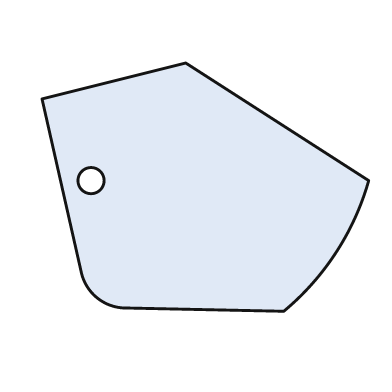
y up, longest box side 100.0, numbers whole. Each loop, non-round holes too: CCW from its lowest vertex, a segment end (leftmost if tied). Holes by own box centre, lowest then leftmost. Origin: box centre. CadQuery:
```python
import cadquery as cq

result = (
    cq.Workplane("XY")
    .moveTo(24.0, -38.0)
    .threePointArc((40.0, -20.0), (50.0, 2.0))
    .lineTo(-6.0, 38.0)
    .lineTo(-50.0, 27.0)
    .lineTo(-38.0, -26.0)
    .threePointArc((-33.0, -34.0), (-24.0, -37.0))
    .close()
    .moveTo(-35.0, 2.0)
    .circle(4.0)
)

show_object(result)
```